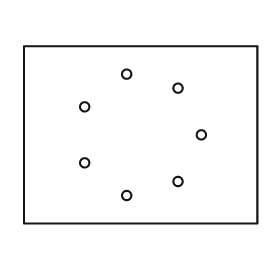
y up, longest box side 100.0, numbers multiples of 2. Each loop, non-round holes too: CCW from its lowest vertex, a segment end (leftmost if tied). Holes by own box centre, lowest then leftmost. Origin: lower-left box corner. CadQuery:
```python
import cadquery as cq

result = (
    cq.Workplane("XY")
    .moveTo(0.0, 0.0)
    .lineTo(100.0, 0.0)
    .lineTo(100.0, 76.0)
    .lineTo(0.0, 76.0)
    .close()
    .moveTo(44.0, 12.0)
    .circle(2.0)
    .moveTo(66.0, 18.0)
    .circle(2.0)
    .moveTo(26.0, 26.0)
    .circle(2.0)
    .moveTo(76.0, 38.0)
    .circle(2.0)
    .moveTo(26.0, 50.0)
    .circle(2.0)
    .moveTo(66.0, 58.0)
    .circle(2.0)
    .moveTo(44.0, 64.0)
    .circle(2.0)
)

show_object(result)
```